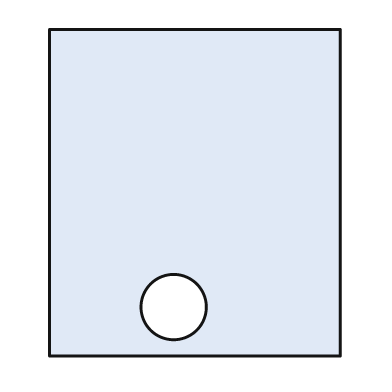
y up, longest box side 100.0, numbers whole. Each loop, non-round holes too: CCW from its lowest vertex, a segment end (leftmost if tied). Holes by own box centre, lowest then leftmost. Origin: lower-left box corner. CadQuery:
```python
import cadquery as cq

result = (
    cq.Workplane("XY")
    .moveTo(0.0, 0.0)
    .lineTo(89.0, 0.0)
    .lineTo(89.0, 100.0)
    .lineTo(0.0, 100.0)
    .close()
    .moveTo(38.0, 15.0)
    .circle(10.0)
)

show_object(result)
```